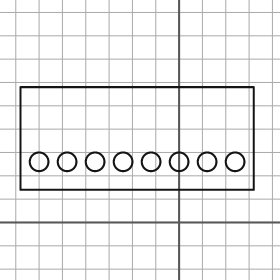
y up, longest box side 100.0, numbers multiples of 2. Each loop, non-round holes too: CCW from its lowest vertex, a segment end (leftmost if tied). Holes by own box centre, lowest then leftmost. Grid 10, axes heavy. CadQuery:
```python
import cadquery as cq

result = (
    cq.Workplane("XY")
    .moveTo(-68.0, 14.0)
    .lineTo(32.0, 14.0)
    .lineTo(32.0, 58.0)
    .lineTo(-68.0, 58.0)
    .close()
    .moveTo(-60.0, 26.0)
    .circle(4.0)
    .moveTo(-48.0, 26.0)
    .circle(4.0)
    .moveTo(-36.0, 26.0)
    .circle(4.0)
    .moveTo(-24.0, 26.0)
    .circle(4.0)
    .moveTo(-12.0, 26.0)
    .circle(4.0)
    .moveTo(0.0, 26.0)
    .circle(4.0)
    .moveTo(12.0, 26.0)
    .circle(4.0)
    .moveTo(24.0, 26.0)
    .circle(4.0)
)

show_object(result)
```